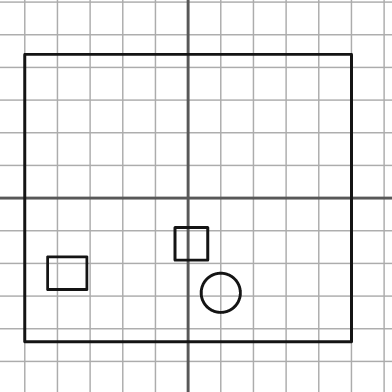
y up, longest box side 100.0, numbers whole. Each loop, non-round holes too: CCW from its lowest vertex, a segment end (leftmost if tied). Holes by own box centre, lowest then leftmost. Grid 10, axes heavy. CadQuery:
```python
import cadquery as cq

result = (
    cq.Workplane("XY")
    .moveTo(-50.0, -44.0)
    .lineTo(50.0, -44.0)
    .lineTo(50.0, 44.0)
    .lineTo(-50.0, 44.0)
    .close()
    .moveTo(10.0, -29.0)
    .circle(6.0)
    .moveTo(-43.0, -28.0)
    .lineTo(-31.0, -28.0)
    .lineTo(-31.0, -18.0)
    .lineTo(-43.0, -18.0)
    .close()
    .moveTo(-4.0, -19.0)
    .lineTo(6.0, -19.0)
    .lineTo(6.0, -9.0)
    .lineTo(-4.0, -9.0)
    .close()
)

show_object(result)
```